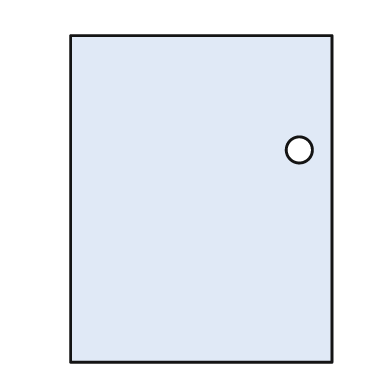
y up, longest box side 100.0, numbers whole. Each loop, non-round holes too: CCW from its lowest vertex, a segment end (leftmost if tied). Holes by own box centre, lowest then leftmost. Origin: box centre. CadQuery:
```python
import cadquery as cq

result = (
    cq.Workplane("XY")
    .moveTo(-40.0, -50.0)
    .lineTo(40.0, -50.0)
    .lineTo(40.0, 50.0)
    .lineTo(-40.0, 50.0)
    .close()
    .moveTo(30.0, 15.0)
    .circle(4.0)
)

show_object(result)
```